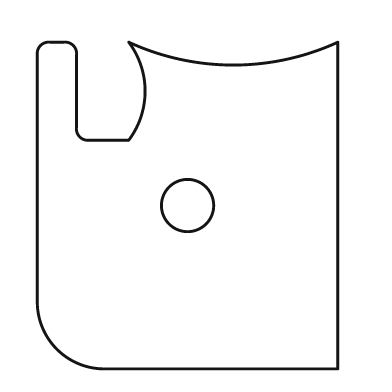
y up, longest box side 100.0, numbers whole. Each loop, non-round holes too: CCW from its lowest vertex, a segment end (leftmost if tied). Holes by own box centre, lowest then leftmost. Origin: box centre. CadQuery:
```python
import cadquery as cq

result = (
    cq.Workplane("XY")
    .moveTo(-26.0, -50.0)
    .lineTo(46.0, -50.0)
    .lineTo(46.0, 50.0)
    .threePointArc((14.0, 43.0), (-18.0, 50.0))
    .threePointArc((-13.0, 35.0), (-18.0, 20.0))
    .lineTo(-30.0, 20.0)
    .threePointArc((-33.0, 21.0), (-34.0, 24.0))
    .lineTo(-34.0, 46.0)
    .threePointArc((-35.0, 49.0), (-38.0, 50.0))
    .lineTo(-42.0, 50.0)
    .threePointArc((-45.0, 49.0), (-46.0, 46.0))
    .lineTo(-46.0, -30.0)
    .threePointArc((-40.0, -44.0), (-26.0, -50.0))
    .close()
    .moveTo(0.0, 0.0)
    .circle(8.0)
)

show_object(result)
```